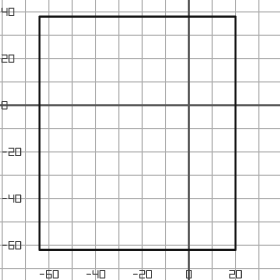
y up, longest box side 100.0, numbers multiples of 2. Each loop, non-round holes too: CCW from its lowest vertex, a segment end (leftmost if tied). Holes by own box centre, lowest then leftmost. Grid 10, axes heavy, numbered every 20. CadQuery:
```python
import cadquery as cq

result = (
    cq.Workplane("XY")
    .moveTo(-64.0, -62.0)
    .lineTo(20.0, -62.0)
    .lineTo(20.0, 38.0)
    .lineTo(-64.0, 38.0)
    .close()
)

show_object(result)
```